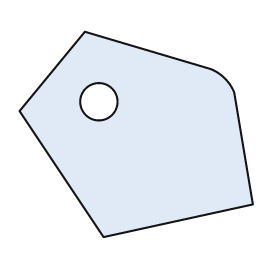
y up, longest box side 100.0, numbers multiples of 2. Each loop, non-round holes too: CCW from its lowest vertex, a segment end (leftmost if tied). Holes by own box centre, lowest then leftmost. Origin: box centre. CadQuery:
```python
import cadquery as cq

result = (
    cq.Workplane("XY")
    .moveTo(-14.0, -44.0)
    .lineTo(50.0, -30.0)
    .lineTo(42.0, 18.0)
    .threePointArc((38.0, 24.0), (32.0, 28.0))
    .lineTo(-22.0, 44.0)
    .lineTo(-50.0, 10.0)
    .close()
    .moveTo(-16.0, 14.0)
    .circle(8.0)
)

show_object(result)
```